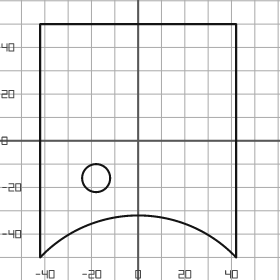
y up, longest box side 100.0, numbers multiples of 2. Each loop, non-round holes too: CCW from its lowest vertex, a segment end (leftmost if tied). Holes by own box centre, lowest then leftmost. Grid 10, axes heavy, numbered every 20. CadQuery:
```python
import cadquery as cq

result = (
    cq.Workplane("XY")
    .moveTo(-42.0, -50.0)
    .threePointArc((0.0, -32.0), (42.0, -50.0))
    .lineTo(42.0, 50.0)
    .lineTo(-42.0, 50.0)
    .close()
    .moveTo(-18.0, -16.0)
    .circle(6.0)
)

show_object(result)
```